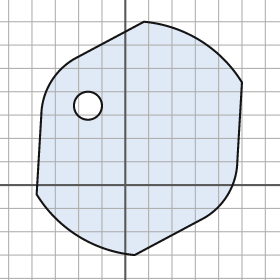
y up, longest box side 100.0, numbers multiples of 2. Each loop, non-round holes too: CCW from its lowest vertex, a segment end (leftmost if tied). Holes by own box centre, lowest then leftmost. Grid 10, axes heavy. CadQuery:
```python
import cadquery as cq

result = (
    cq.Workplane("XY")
    .moveTo(4.0, -30.0)
    .lineTo(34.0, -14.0)
    .threePointArc((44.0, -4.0), (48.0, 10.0))
    .lineTo(50.0, 44.0)
    .threePointArc((32.0, 62.0), (8.0, 70.0))
    .lineTo(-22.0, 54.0)
    .threePointArc((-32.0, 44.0), (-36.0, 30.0))
    .lineTo(-38.0, -4.0)
    .threePointArc((-20.0, -22.0), (4.0, -30.0))
    .close()
    .moveTo(-16.0, 34.0)
    .circle(6.0)
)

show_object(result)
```